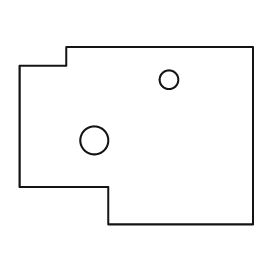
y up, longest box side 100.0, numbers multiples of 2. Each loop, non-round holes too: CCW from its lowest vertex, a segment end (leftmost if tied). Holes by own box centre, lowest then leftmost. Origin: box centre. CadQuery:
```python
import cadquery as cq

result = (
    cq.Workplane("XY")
    .moveTo(-12.0, -38.0)
    .lineTo(50.0, -38.0)
    .lineTo(50.0, 38.0)
    .lineTo(-30.0, 38.0)
    .lineTo(-30.0, 30.0)
    .lineTo(-50.0, 30.0)
    .lineTo(-50.0, -22.0)
    .lineTo(-12.0, -22.0)
    .close()
    .moveTo(-18.0, -2.0)
    .circle(6.0)
    .moveTo(14.0, 24.0)
    .circle(4.0)
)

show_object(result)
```